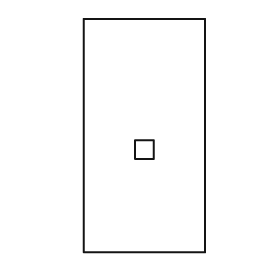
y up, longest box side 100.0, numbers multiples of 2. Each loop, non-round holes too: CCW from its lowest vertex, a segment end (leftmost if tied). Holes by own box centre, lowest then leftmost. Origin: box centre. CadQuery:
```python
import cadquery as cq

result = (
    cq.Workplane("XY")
    .moveTo(-26.0, -50.0)
    .lineTo(26.0, -50.0)
    .lineTo(26.0, 50.0)
    .lineTo(-26.0, 50.0)
    .close()
    .moveTo(-4.0, -10.0)
    .lineTo(4.0, -10.0)
    .lineTo(4.0, -2.0)
    .lineTo(-4.0, -2.0)
    .close()
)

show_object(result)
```